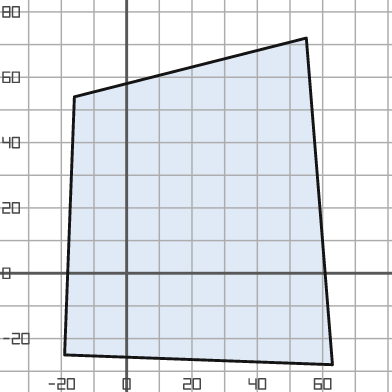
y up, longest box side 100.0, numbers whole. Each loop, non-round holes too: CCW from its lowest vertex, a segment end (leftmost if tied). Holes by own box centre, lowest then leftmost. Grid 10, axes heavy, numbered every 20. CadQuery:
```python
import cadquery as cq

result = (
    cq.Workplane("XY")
    .moveTo(63.0, -28.0)
    .lineTo(55.0, 72.0)
    .lineTo(-16.0, 54.0)
    .lineTo(-19.0, -25.0)
    .close()
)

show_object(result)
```